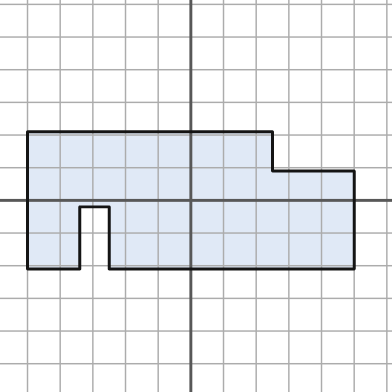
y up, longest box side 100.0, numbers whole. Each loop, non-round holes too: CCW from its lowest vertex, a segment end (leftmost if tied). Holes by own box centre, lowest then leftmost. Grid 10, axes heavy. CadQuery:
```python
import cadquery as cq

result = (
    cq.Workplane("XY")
    .moveTo(-50.0, -21.0)
    .lineTo(-34.0, -21.0)
    .lineTo(-34.0, -2.0)
    .lineTo(-25.0, -2.0)
    .lineTo(-25.0, -21.0)
    .lineTo(50.0, -21.0)
    .lineTo(50.0, 9.0)
    .lineTo(25.0, 9.0)
    .lineTo(25.0, 21.0)
    .lineTo(-50.0, 21.0)
    .close()
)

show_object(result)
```